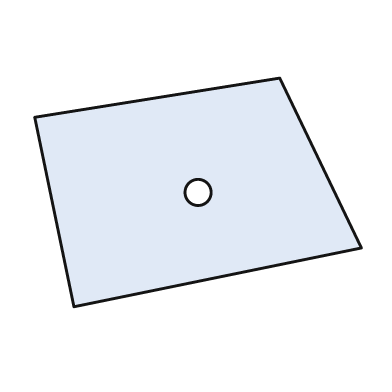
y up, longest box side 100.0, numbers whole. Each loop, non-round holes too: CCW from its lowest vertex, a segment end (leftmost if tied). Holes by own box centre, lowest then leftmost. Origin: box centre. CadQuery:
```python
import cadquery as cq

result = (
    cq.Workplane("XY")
    .moveTo(-38.0, -35.0)
    .lineTo(50.0, -17.0)
    .lineTo(25.0, 35.0)
    .lineTo(-50.0, 23.0)
    .close()
    .moveTo(0.0, 0.0)
    .circle(4.0)
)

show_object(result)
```